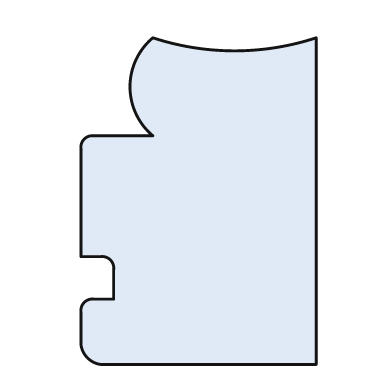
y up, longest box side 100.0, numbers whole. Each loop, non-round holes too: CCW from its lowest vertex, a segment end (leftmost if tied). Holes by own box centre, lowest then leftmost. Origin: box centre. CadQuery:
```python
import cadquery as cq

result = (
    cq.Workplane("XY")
    .moveTo(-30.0, -50.0)
    .lineTo(36.0, -50.0)
    .lineTo(36.0, 50.0)
    .threePointArc((11.0, 46.0), (-14.0, 50.0))
    .threePointArc((-21.0, 35.0), (-14.0, 20.0))
    .lineTo(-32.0, 20.0)
    .threePointArc((-35.0, 19.0), (-36.0, 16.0))
    .lineTo(-36.0, -17.0)
    .lineTo(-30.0, -17.0)
    .threePointArc((-27.0, -18.0), (-26.0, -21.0))
    .lineTo(-26.0, -30.0)
    .lineTo(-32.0, -30.0)
    .threePointArc((-35.0, -31.0), (-36.0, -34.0))
    .lineTo(-36.0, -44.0)
    .threePointArc((-34.0, -48.0), (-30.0, -50.0))
    .close()
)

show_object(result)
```